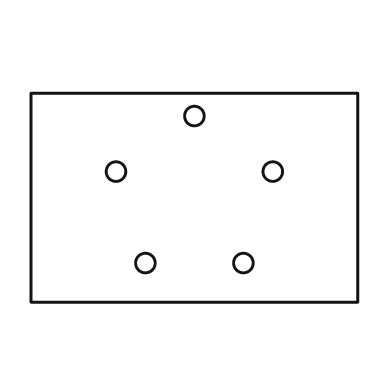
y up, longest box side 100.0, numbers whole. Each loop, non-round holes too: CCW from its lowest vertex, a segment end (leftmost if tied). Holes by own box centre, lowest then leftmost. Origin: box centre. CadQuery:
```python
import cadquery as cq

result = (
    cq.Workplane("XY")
    .moveTo(-50.0, -32.0)
    .lineTo(50.0, -32.0)
    .lineTo(50.0, 32.0)
    .lineTo(-50.0, 32.0)
    .close()
    .moveTo(-15.0, -20.0)
    .circle(3.0)
    .moveTo(15.0, -20.0)
    .circle(3.0)
    .moveTo(-24.0, 8.0)
    .circle(3.0)
    .moveTo(24.0, 8.0)
    .circle(3.0)
    .moveTo(0.0, 25.0)
    .circle(3.0)
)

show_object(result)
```